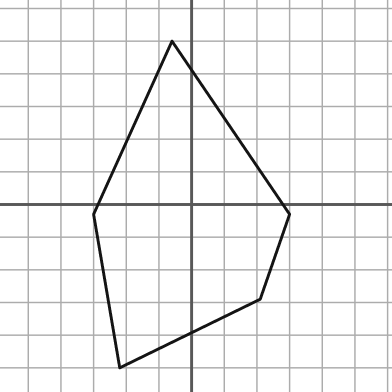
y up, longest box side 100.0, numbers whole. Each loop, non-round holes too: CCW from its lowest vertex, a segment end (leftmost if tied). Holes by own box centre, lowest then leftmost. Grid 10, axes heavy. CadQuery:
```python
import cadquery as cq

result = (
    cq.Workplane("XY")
    .moveTo(-22.0, -50.0)
    .lineTo(21.0, -29.0)
    .lineTo(30.0, -3.0)
    .lineTo(-6.0, 50.0)
    .lineTo(-30.0, -3.0)
    .close()
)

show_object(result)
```